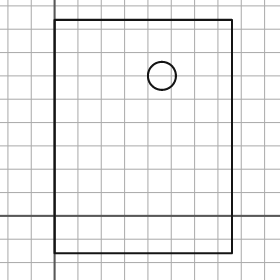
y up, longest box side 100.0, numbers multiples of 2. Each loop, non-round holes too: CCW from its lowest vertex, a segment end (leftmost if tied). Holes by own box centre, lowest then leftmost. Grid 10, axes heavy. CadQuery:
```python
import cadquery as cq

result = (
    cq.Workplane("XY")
    .moveTo(0.0, -16.0)
    .lineTo(76.0, -16.0)
    .lineTo(76.0, 84.0)
    .lineTo(0.0, 84.0)
    .close()
    .moveTo(46.0, 60.0)
    .circle(6.0)
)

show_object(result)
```